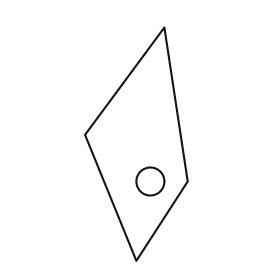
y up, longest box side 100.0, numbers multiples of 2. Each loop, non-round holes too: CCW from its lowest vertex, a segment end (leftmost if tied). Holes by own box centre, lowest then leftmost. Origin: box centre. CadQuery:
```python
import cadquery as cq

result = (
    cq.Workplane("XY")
    .moveTo(0.0, -50.0)
    .lineTo(22.0, -16.0)
    .lineTo(12.0, 50.0)
    .lineTo(-22.0, 4.0)
    .close()
    .moveTo(6.0, -16.0)
    .circle(6.0)
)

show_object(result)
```